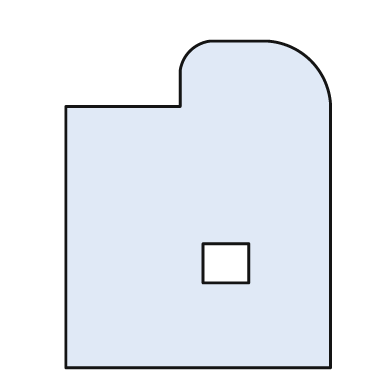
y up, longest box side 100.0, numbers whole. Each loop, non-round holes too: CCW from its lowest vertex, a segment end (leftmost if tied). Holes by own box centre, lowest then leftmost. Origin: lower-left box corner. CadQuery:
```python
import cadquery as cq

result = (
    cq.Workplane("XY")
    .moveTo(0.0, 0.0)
    .lineTo(81.0, 0.0)
    .lineTo(81.0, 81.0)
    .threePointArc((75.0, 94.0), (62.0, 100.0))
    .lineTo(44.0, 100.0)
    .threePointArc((38.0, 97.0), (35.0, 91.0))
    .lineTo(35.0, 80.0)
    .lineTo(0.0, 80.0)
    .close()
    .moveTo(42.0, 26.0)
    .lineTo(56.0, 26.0)
    .lineTo(56.0, 38.0)
    .lineTo(42.0, 38.0)
    .close()
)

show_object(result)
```